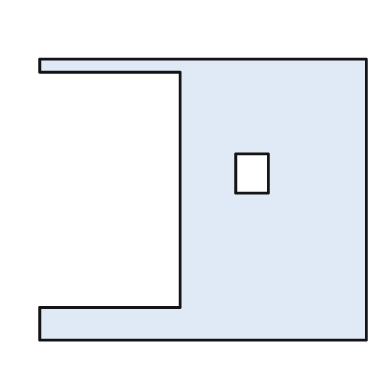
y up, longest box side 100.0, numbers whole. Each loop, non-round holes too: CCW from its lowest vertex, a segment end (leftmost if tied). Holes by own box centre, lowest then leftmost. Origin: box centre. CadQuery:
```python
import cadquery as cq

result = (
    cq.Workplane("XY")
    .moveTo(-50.0, -43.0)
    .lineTo(50.0, -43.0)
    .lineTo(50.0, 43.0)
    .lineTo(-50.0, 43.0)
    .lineTo(-50.0, 39.0)
    .lineTo(-7.0, 39.0)
    .lineTo(-7.0, -33.0)
    .lineTo(-50.0, -33.0)
    .close()
    .moveTo(10.0, 2.0)
    .lineTo(20.0, 2.0)
    .lineTo(20.0, 14.0)
    .lineTo(10.0, 14.0)
    .close()
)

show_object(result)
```